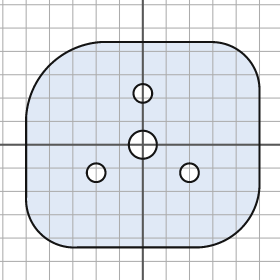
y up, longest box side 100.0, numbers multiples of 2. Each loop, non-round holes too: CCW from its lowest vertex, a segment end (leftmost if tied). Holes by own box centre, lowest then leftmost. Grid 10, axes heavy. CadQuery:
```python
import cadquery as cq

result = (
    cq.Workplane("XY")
    .moveTo(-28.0, -44.0)
    .lineTo(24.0, -44.0)
    .threePointArc((42.0, -36.0), (50.0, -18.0))
    .lineTo(50.0, 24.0)
    .threePointArc((44.0, 38.0), (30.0, 44.0))
    .lineTo(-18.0, 44.0)
    .threePointArc((-40.0, 34.0), (-50.0, 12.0))
    .lineTo(-50.0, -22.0)
    .threePointArc((-44.0, -38.0), (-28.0, -44.0))
    .close()
    .moveTo(-20.0, -12.0)
    .circle(4.0)
    .moveTo(20.0, -12.0)
    .circle(4.0)
    .moveTo(0.0, 0.0)
    .circle(6.0)
    .moveTo(0.0, 22.0)
    .circle(4.0)
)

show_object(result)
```